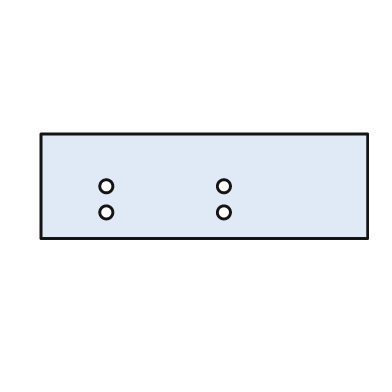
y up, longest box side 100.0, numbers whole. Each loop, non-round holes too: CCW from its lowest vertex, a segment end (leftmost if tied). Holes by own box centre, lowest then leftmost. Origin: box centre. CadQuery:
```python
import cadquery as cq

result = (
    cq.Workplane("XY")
    .moveTo(-50.0, -16.0)
    .lineTo(50.0, -16.0)
    .lineTo(50.0, 16.0)
    .lineTo(-50.0, 16.0)
    .close()
    .moveTo(-30.0, -8.0)
    .circle(2.0)
    .moveTo(6.0, -8.0)
    .circle(2.0)
    .moveTo(-30.0, 0.0)
    .circle(2.0)
    .moveTo(6.0, 0.0)
    .circle(2.0)
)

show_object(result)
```